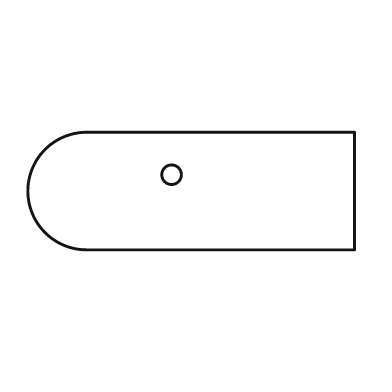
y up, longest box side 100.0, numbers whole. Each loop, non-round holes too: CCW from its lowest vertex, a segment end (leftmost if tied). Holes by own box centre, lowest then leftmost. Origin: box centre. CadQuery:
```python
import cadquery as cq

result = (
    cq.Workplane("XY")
    .moveTo(-32.0, -18.0)
    .lineTo(50.0, -18.0)
    .lineTo(50.0, 18.0)
    .lineTo(-32.0, 18.0)
    .threePointArc((-50.0, 0.0), (-32.0, -18.0))
    .close()
    .moveTo(-6.0, 5.0)
    .circle(3.0)
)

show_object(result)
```